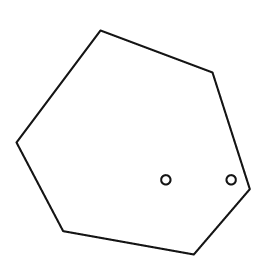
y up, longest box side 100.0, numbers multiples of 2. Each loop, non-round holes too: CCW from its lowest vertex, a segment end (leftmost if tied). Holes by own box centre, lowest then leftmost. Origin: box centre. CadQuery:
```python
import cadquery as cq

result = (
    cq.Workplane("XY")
    .moveTo(26.0, -48.0)
    .lineTo(50.0, -20.0)
    .lineTo(34.0, 30.0)
    .lineTo(-14.0, 48.0)
    .lineTo(-50.0, 0.0)
    .lineTo(-30.0, -38.0)
    .close()
    .moveTo(14.0, -16.0)
    .circle(2.0)
    .moveTo(42.0, -16.0)
    .circle(2.0)
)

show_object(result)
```